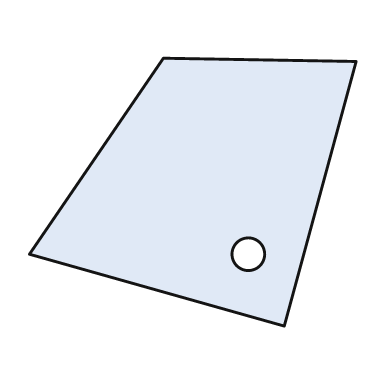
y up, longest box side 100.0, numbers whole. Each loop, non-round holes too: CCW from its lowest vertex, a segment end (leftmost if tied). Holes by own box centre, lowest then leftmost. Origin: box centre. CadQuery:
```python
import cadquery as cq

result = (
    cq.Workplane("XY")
    .moveTo(28.0, -41.0)
    .lineTo(50.0, 40.0)
    .lineTo(-9.0, 41.0)
    .lineTo(-50.0, -19.0)
    .close()
    .moveTo(17.0, -19.0)
    .circle(5.0)
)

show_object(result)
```